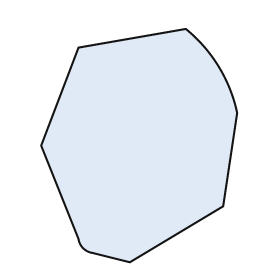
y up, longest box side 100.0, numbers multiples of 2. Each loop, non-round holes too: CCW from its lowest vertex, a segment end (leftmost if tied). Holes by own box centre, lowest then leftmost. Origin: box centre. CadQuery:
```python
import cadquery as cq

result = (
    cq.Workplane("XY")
    .moveTo(-4.0, -50.0)
    .lineTo(36.0, -26.0)
    .lineTo(42.0, 14.0)
    .threePointArc((34.0, 34.0), (20.0, 50.0))
    .lineTo(-26.0, 42.0)
    .lineTo(-42.0, 0.0)
    .lineTo(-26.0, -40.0)
    .threePointArc((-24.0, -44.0), (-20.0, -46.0))
    .close()
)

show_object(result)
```